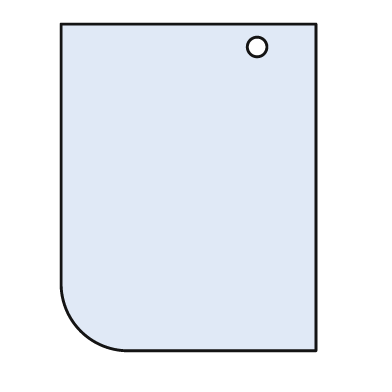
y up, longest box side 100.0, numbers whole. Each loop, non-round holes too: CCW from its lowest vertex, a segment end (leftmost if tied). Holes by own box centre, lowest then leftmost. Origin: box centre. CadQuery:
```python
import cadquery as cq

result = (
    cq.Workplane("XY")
    .moveTo(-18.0, -50.0)
    .lineTo(39.0, -50.0)
    .lineTo(39.0, 50.0)
    .lineTo(-39.0, 50.0)
    .lineTo(-39.0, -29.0)
    .threePointArc((-33.0, -44.0), (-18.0, -50.0))
    .close()
    .moveTo(21.0, 43.0)
    .circle(3.0)
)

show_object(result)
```